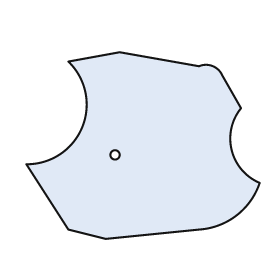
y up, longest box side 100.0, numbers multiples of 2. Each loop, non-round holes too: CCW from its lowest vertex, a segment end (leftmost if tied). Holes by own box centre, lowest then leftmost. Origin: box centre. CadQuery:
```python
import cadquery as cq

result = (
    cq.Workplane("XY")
    .moveTo(-16.0, -40.0)
    .lineTo(24.0, -36.0)
    .threePointArc((40.0, -30.0), (50.0, -16.0))
    .threePointArc((38.0, -2.0), (42.0, 16.0))
    .lineTo(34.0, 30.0)
    .threePointArc((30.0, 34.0), (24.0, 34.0))
    .lineTo(-10.0, 40.0)
    .lineTo(-32.0, 36.0)
    .threePointArc((-26.0, 8.0), (-50.0, -8.0))
    .lineTo(-32.0, -36.0)
    .close()
    .moveTo(-12.0, -4.0)
    .circle(2.0)
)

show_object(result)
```